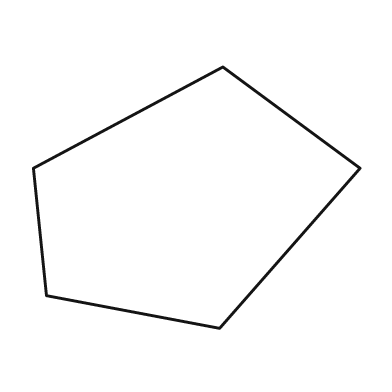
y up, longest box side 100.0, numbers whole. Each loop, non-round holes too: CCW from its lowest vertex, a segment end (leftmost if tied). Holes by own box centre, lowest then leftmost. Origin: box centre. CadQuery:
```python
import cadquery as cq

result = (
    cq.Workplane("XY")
    .moveTo(7.0, -40.0)
    .lineTo(50.0, 9.0)
    .lineTo(8.0, 40.0)
    .lineTo(-50.0, 9.0)
    .lineTo(-46.0, -30.0)
    .close()
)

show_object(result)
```